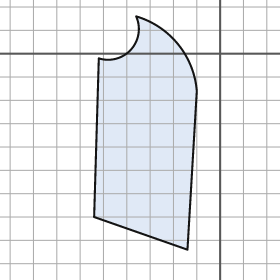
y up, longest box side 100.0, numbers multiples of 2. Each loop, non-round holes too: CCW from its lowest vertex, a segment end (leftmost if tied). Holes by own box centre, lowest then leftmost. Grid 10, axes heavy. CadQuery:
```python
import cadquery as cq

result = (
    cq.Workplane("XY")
    .moveTo(-14.0, -84.0)
    .lineTo(-10.0, -16.0)
    .threePointArc((-18.0, 4.0), (-36.0, 16.0))
    .threePointArc((-38.0, 2.0), (-52.0, -2.0))
    .lineTo(-54.0, -70.0)
    .close()
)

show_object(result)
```